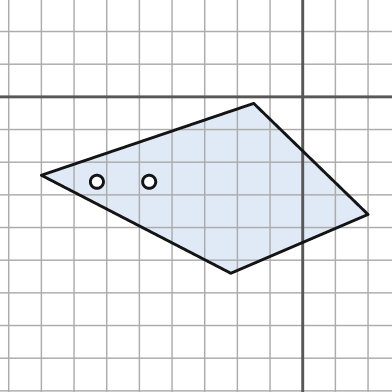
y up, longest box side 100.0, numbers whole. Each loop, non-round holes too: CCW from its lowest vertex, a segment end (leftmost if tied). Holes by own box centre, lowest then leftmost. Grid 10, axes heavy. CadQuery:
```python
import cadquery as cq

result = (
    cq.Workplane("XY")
    .moveTo(-22.0, -54.0)
    .lineTo(20.0, -36.0)
    .lineTo(-15.0, -2.0)
    .lineTo(-80.0, -24.0)
    .close()
    .moveTo(-63.0, -26.0)
    .circle(2.0)
    .moveTo(-47.0, -26.0)
    .circle(2.0)
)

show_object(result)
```